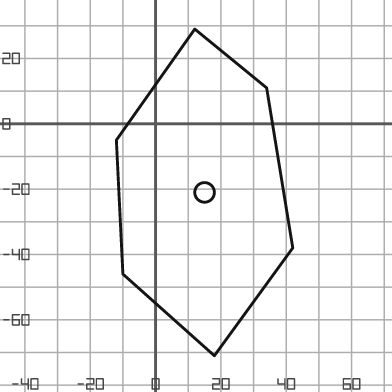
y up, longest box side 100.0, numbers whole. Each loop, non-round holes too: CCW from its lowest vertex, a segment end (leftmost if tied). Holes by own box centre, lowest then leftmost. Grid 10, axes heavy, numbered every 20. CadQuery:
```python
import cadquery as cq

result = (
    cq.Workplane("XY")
    .moveTo(18.0, -71.0)
    .lineTo(42.0, -38.0)
    .lineTo(34.0, 11.0)
    .lineTo(12.0, 29.0)
    .lineTo(-12.0, -5.0)
    .lineTo(-10.0, -46.0)
    .close()
    .moveTo(15.0, -21.0)
    .circle(3.0)
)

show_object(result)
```